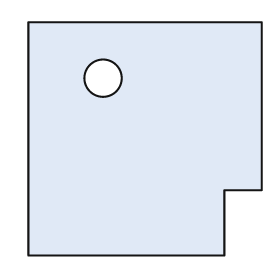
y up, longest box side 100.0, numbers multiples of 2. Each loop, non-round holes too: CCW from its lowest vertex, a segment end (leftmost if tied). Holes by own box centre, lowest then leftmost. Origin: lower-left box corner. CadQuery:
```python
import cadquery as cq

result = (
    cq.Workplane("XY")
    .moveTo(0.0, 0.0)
    .lineTo(84.0, 0.0)
    .lineTo(84.0, 28.0)
    .lineTo(100.0, 28.0)
    .lineTo(100.0, 100.0)
    .lineTo(0.0, 100.0)
    .close()
    .moveTo(32.0, 76.0)
    .circle(8.0)
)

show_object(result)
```